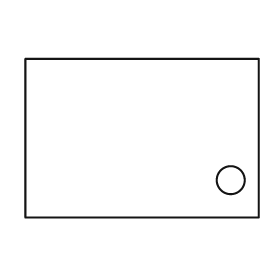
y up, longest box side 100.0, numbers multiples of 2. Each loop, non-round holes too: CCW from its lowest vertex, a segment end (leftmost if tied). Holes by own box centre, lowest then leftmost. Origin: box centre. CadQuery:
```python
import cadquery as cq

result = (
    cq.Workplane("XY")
    .moveTo(-50.0, -34.0)
    .lineTo(50.0, -34.0)
    .lineTo(50.0, 34.0)
    .lineTo(-50.0, 34.0)
    .close()
    .moveTo(38.0, -18.0)
    .circle(6.0)
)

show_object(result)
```